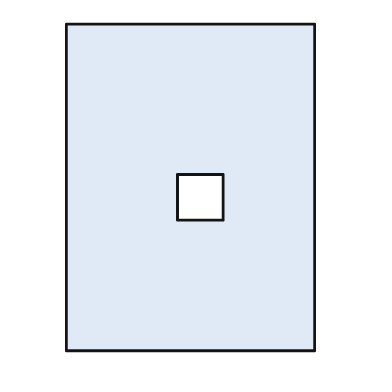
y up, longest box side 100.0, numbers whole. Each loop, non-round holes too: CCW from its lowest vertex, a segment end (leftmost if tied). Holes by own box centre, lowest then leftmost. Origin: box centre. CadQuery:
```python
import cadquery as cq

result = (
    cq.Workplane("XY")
    .moveTo(-38.0, -50.0)
    .lineTo(38.0, -50.0)
    .lineTo(38.0, 50.0)
    .lineTo(-38.0, 50.0)
    .close()
    .moveTo(-4.0, -10.0)
    .lineTo(10.0, -10.0)
    .lineTo(10.0, 4.0)
    .lineTo(-4.0, 4.0)
    .close()
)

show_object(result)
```